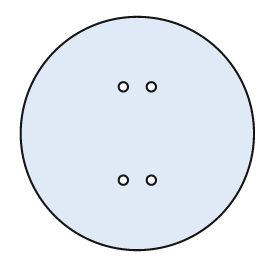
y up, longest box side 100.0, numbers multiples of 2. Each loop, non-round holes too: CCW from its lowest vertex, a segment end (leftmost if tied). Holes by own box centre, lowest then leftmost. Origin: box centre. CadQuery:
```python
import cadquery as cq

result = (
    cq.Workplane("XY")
    .moveTo(0.0, 0.0)
    .circle(50.0)
    .moveTo(-6.0, -20.0)
    .circle(2.0)
    .moveTo(6.0, -20.0)
    .circle(2.0)
    .moveTo(-6.0, 20.0)
    .circle(2.0)
    .moveTo(6.0, 20.0)
    .circle(2.0)
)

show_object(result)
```